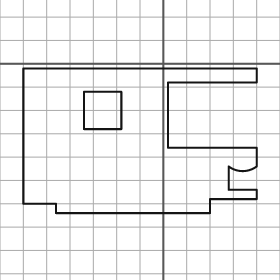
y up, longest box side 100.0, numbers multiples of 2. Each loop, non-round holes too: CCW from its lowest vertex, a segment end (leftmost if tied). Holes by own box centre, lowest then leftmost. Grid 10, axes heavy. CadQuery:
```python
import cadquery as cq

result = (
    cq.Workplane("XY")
    .moveTo(-46.0, -64.0)
    .lineTo(20.0, -64.0)
    .lineTo(20.0, -58.0)
    .lineTo(40.0, -58.0)
    .lineTo(40.0, -54.0)
    .lineTo(28.0, -54.0)
    .lineTo(28.0, -44.0)
    .threePointArc((34.0, -46.0), (40.0, -44.0))
    .lineTo(40.0, -36.0)
    .lineTo(2.0, -36.0)
    .lineTo(2.0, -8.0)
    .lineTo(40.0, -8.0)
    .lineTo(40.0, -2.0)
    .lineTo(-60.0, -2.0)
    .lineTo(-60.0, -60.0)
    .lineTo(-46.0, -60.0)
    .close()
    .moveTo(-34.0, -28.0)
    .lineTo(-18.0, -28.0)
    .lineTo(-18.0, -12.0)
    .lineTo(-34.0, -12.0)
    .close()
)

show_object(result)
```